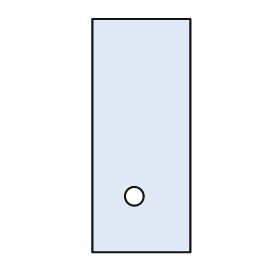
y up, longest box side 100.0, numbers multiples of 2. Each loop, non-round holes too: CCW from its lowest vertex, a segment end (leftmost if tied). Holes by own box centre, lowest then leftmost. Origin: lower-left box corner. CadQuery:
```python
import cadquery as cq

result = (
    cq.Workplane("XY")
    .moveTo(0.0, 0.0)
    .lineTo(42.0, 0.0)
    .lineTo(42.0, 100.0)
    .lineTo(0.0, 100.0)
    .close()
    .moveTo(18.0, 24.0)
    .circle(4.0)
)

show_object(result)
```